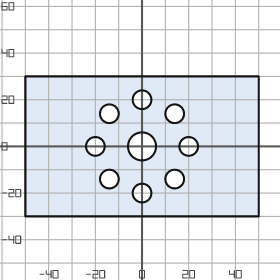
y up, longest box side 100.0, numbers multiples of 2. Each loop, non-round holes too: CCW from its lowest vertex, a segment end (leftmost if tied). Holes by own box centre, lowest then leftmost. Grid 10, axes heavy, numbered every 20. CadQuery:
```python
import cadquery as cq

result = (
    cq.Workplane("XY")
    .moveTo(-50.0, -30.0)
    .lineTo(50.0, -30.0)
    .lineTo(50.0, 30.0)
    .lineTo(-50.0, 30.0)
    .close()
    .moveTo(0.0, -20.0)
    .circle(4.0)
    .moveTo(-14.0, -14.0)
    .circle(4.0)
    .moveTo(14.0, -14.0)
    .circle(4.0)
    .moveTo(-20.0, 0.0)
    .circle(4.0)
    .moveTo(0.0, 0.0)
    .circle(6.0)
    .moveTo(20.0, 0.0)
    .circle(4.0)
    .moveTo(-14.0, 14.0)
    .circle(4.0)
    .moveTo(14.0, 14.0)
    .circle(4.0)
    .moveTo(0.0, 20.0)
    .circle(4.0)
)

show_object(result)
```